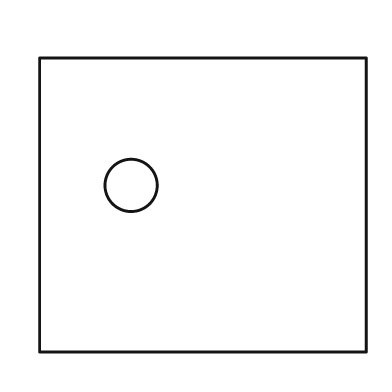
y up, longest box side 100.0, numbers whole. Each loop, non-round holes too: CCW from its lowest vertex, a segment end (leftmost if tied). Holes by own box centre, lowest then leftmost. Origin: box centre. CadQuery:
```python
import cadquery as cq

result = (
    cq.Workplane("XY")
    .moveTo(-50.0, -45.0)
    .lineTo(50.0, -45.0)
    .lineTo(50.0, 45.0)
    .lineTo(-50.0, 45.0)
    .close()
    .moveTo(-22.0, 6.0)
    .circle(8.0)
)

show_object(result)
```